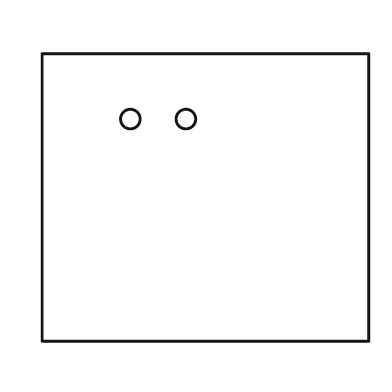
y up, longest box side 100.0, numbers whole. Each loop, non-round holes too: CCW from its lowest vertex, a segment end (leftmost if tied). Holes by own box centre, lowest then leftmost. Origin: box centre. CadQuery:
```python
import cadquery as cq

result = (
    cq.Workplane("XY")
    .moveTo(-50.0, -44.0)
    .lineTo(50.0, -44.0)
    .lineTo(50.0, 44.0)
    .lineTo(-50.0, 44.0)
    .close()
    .moveTo(-23.0, 24.0)
    .circle(3.0)
    .moveTo(-6.0, 24.0)
    .circle(3.0)
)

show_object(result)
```